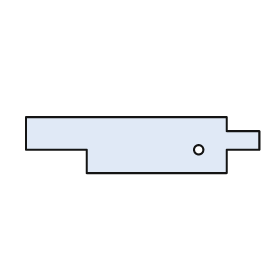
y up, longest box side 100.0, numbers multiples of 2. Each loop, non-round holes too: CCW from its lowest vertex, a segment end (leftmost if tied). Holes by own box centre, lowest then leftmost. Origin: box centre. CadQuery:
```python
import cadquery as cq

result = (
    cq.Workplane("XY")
    .moveTo(-24.0, -12.0)
    .lineTo(36.0, -12.0)
    .lineTo(36.0, -2.0)
    .lineTo(50.0, -2.0)
    .lineTo(50.0, 6.0)
    .lineTo(36.0, 6.0)
    .lineTo(36.0, 12.0)
    .lineTo(-50.0, 12.0)
    .lineTo(-50.0, -2.0)
    .lineTo(-24.0, -2.0)
    .close()
    .moveTo(24.0, -2.0)
    .circle(2.0)
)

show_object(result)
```